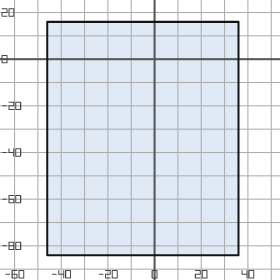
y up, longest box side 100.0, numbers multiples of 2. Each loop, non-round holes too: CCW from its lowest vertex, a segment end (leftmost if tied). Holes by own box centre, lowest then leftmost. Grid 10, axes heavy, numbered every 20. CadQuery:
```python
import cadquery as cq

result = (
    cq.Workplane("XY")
    .moveTo(-46.0, -84.0)
    .lineTo(36.0, -84.0)
    .lineTo(36.0, 16.0)
    .lineTo(-46.0, 16.0)
    .close()
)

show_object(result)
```